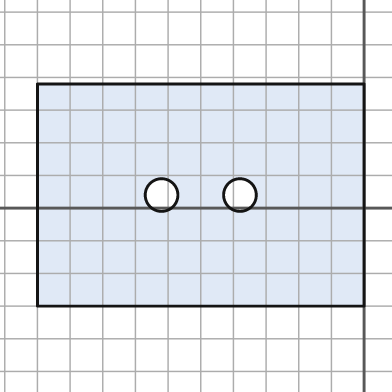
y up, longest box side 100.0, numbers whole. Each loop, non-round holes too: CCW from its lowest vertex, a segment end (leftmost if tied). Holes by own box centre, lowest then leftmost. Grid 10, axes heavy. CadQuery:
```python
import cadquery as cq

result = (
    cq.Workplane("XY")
    .moveTo(-100.0, -30.0)
    .lineTo(0.0, -30.0)
    .lineTo(0.0, 38.0)
    .lineTo(-100.0, 38.0)
    .close()
    .moveTo(-62.0, 4.0)
    .circle(5.0)
    .moveTo(-38.0, 4.0)
    .circle(5.0)
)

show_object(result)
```